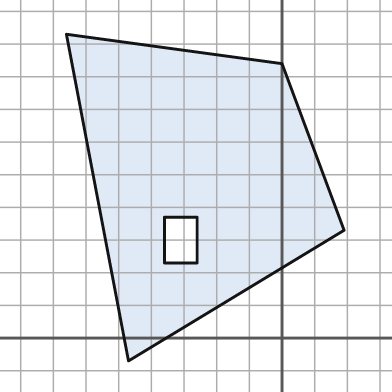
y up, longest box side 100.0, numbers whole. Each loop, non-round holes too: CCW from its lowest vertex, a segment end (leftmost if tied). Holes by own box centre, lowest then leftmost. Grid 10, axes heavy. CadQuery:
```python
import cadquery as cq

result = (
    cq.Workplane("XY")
    .moveTo(-47.0, -7.0)
    .lineTo(19.0, 33.0)
    .lineTo(0.0, 84.0)
    .lineTo(-66.0, 93.0)
    .close()
    .moveTo(-36.0, 23.0)
    .lineTo(-26.0, 23.0)
    .lineTo(-26.0, 37.0)
    .lineTo(-36.0, 37.0)
    .close()
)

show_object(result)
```